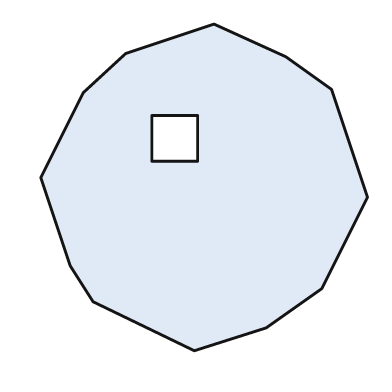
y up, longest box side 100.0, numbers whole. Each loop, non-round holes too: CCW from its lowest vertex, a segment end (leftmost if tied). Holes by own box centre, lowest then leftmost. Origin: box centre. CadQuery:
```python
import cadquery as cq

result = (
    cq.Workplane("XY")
    .moveTo(-3.0, -50.0)
    .lineTo(19.0, -43.0)
    .lineTo(36.0, -31.0)
    .lineTo(50.0, -3.0)
    .lineTo(39.0, 30.0)
    .lineTo(25.0, 40.0)
    .lineTo(3.0, 50.0)
    .lineTo(-24.0, 41.0)
    .lineTo(-37.0, 29.0)
    .lineTo(-50.0, 3.0)
    .lineTo(-41.0, -24.0)
    .lineTo(-34.0, -35.0)
    .close()
    .moveTo(-16.0, 8.0)
    .lineTo(-2.0, 8.0)
    .lineTo(-2.0, 22.0)
    .lineTo(-16.0, 22.0)
    .close()
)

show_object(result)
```